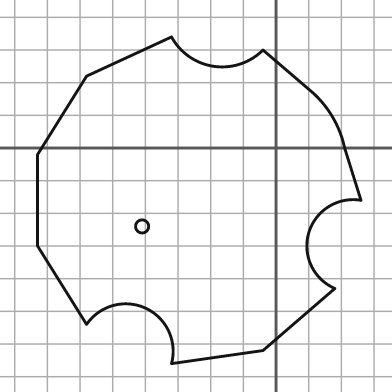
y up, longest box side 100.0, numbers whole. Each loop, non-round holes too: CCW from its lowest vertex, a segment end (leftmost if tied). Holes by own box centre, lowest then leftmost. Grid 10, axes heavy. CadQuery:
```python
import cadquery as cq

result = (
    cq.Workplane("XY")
    .moveTo(-32.0, -66.0)
    .lineTo(-4.0, -62.0)
    .lineTo(18.0, -43.0)
    .threePointArc((10.0, -26.0), (26.0, -16.0))
    .lineTo(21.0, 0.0)
    .threePointArc((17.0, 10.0), (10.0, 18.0))
    .lineTo(-4.0, 30.0)
    .threePointArc((-19.0, 25.0), (-32.0, 34.0))
    .lineTo(-58.0, 22.0)
    .lineTo(-73.0, -2.0)
    .lineTo(-73.0, -30.0)
    .lineTo(-58.0, -54.0)
    .threePointArc((-40.0, -49.0), (-32.0, -66.0))
    .close()
    .moveTo(-41.0, -24.0)
    .circle(2.0)
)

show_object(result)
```